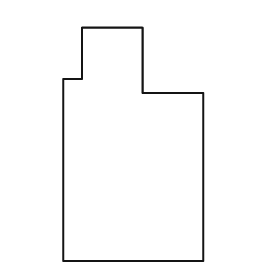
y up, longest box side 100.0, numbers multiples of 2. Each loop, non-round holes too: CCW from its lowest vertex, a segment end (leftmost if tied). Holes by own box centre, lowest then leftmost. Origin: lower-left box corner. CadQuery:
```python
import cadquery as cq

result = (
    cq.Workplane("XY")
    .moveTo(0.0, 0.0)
    .lineTo(60.0, 0.0)
    .lineTo(60.0, 72.0)
    .lineTo(34.0, 72.0)
    .lineTo(34.0, 100.0)
    .lineTo(8.0, 100.0)
    .lineTo(8.0, 78.0)
    .lineTo(0.0, 78.0)
    .close()
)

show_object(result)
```